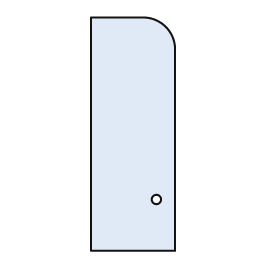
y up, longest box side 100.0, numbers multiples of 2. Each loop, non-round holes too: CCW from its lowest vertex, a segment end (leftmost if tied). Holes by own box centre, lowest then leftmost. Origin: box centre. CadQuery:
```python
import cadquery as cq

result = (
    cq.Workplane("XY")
    .moveTo(-18.0, -50.0)
    .lineTo(18.0, -50.0)
    .lineTo(18.0, 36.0)
    .threePointArc((14.0, 46.0), (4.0, 50.0))
    .lineTo(-18.0, 50.0)
    .close()
    .moveTo(10.0, -28.0)
    .circle(2.0)
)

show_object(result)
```